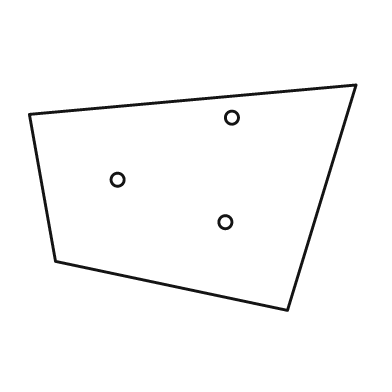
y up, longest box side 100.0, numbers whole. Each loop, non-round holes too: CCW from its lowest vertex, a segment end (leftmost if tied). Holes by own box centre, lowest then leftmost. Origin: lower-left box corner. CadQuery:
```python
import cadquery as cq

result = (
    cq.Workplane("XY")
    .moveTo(79.0, 0.0)
    .lineTo(100.0, 69.0)
    .lineTo(0.0, 60.0)
    .lineTo(8.0, 15.0)
    .close()
    .moveTo(60.0, 27.0)
    .circle(2.0)
    .moveTo(27.0, 40.0)
    .circle(2.0)
    .moveTo(62.0, 59.0)
    .circle(2.0)
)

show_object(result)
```